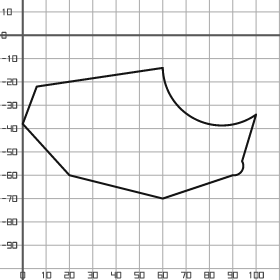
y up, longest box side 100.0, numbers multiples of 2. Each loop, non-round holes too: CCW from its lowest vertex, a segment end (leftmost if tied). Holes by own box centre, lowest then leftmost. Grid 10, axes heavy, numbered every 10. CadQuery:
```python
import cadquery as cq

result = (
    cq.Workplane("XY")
    .moveTo(60.0, -70.0)
    .lineTo(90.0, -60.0)
    .threePointArc((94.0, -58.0), (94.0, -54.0))
    .lineTo(100.0, -34.0)
    .threePointArc((74.0, -36.0), (60.0, -14.0))
    .lineTo(6.0, -22.0)
    .lineTo(0.0, -38.0)
    .lineTo(20.0, -60.0)
    .close()
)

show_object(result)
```